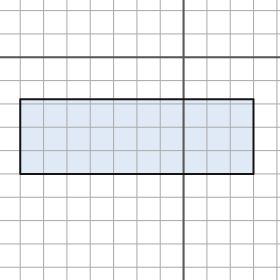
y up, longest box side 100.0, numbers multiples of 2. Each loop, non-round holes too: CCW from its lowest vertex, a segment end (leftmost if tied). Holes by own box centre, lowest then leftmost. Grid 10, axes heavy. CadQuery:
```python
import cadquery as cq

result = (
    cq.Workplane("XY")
    .moveTo(-70.0, -50.0)
    .lineTo(30.0, -50.0)
    .lineTo(30.0, -18.0)
    .lineTo(-70.0, -18.0)
    .close()
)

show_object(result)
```